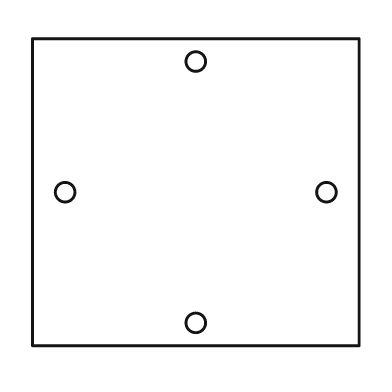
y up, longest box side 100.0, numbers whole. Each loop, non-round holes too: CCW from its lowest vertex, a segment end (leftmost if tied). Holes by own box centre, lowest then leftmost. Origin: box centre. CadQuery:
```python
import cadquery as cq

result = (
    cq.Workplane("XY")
    .moveTo(-50.0, -47.0)
    .lineTo(50.0, -47.0)
    .lineTo(50.0, 47.0)
    .lineTo(-50.0, 47.0)
    .close()
    .moveTo(0.0, -40.0)
    .circle(3.0)
    .moveTo(-40.0, 0.0)
    .circle(3.0)
    .moveTo(40.0, 0.0)
    .circle(3.0)
    .moveTo(0.0, 40.0)
    .circle(3.0)
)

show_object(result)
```